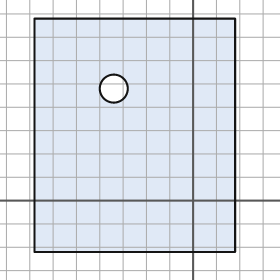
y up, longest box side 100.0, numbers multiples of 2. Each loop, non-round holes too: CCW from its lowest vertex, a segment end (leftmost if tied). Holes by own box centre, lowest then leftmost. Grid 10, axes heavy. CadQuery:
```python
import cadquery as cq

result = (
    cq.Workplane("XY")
    .moveTo(-68.0, -22.0)
    .lineTo(18.0, -22.0)
    .lineTo(18.0, 78.0)
    .lineTo(-68.0, 78.0)
    .close()
    .moveTo(-34.0, 48.0)
    .circle(6.0)
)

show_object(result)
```